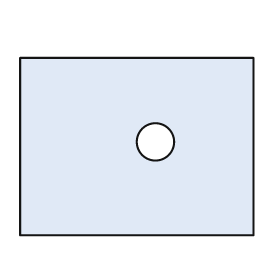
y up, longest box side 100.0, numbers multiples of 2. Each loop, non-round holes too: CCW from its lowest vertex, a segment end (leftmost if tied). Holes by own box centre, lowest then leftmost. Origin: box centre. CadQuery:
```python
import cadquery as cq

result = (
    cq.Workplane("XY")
    .moveTo(-50.0, -38.0)
    .lineTo(50.0, -38.0)
    .lineTo(50.0, 38.0)
    .lineTo(-50.0, 38.0)
    .close()
    .moveTo(8.0, 2.0)
    .circle(8.0)
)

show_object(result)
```